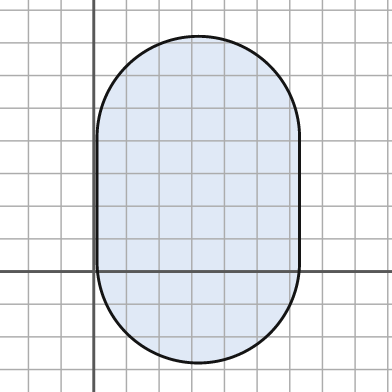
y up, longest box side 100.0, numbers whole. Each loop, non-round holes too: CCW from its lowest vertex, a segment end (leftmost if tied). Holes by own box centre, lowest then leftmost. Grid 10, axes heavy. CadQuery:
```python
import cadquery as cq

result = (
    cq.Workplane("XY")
    .moveTo(1.0, 3.0)
    .threePointArc((32.0, -28.0), (63.0, 3.0))
    .lineTo(63.0, 41.0)
    .threePointArc((32.0, 72.0), (1.0, 41.0))
    .close()
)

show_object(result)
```